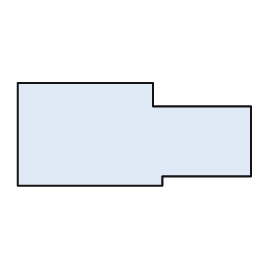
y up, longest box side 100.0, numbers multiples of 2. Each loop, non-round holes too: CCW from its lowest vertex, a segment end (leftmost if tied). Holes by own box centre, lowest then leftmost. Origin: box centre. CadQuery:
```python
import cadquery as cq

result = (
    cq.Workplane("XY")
    .moveTo(-50.0, -22.0)
    .lineTo(12.0, -22.0)
    .lineTo(12.0, -18.0)
    .lineTo(50.0, -18.0)
    .lineTo(50.0, 12.0)
    .lineTo(8.0, 12.0)
    .lineTo(8.0, 22.0)
    .lineTo(-50.0, 22.0)
    .close()
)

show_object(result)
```